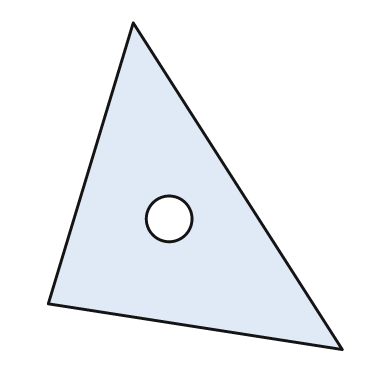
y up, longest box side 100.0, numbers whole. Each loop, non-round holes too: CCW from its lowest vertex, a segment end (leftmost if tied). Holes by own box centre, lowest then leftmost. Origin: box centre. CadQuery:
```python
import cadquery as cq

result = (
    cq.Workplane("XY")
    .moveTo(45.0, -50.0)
    .lineTo(-19.0, 50.0)
    .lineTo(-45.0, -36.0)
    .close()
    .moveTo(-8.0, -10.0)
    .circle(7.0)
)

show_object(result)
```